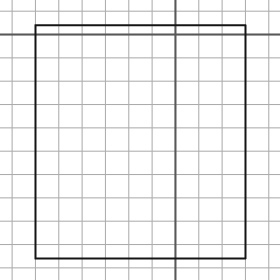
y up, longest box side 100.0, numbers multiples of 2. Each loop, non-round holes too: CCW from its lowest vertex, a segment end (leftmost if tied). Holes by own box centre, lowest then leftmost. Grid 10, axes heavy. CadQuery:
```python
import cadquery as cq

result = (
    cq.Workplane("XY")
    .moveTo(-60.0, -96.0)
    .lineTo(30.0, -96.0)
    .lineTo(30.0, 4.0)
    .lineTo(-60.0, 4.0)
    .close()
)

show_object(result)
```